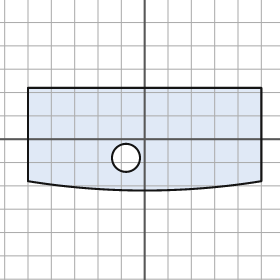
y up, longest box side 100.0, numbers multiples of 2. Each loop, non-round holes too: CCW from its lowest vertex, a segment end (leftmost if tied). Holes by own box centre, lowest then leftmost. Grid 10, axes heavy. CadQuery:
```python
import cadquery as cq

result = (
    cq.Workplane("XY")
    .moveTo(-50.0, -18.0)
    .threePointArc((0.0, -22.0), (50.0, -18.0))
    .lineTo(50.0, 22.0)
    .lineTo(-50.0, 22.0)
    .close()
    .moveTo(-8.0, -8.0)
    .circle(6.0)
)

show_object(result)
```